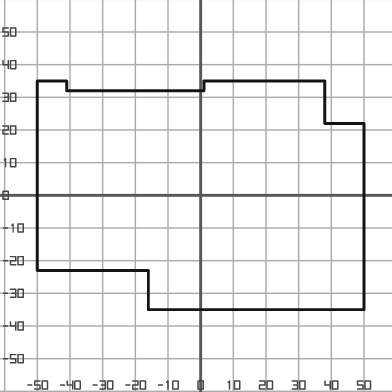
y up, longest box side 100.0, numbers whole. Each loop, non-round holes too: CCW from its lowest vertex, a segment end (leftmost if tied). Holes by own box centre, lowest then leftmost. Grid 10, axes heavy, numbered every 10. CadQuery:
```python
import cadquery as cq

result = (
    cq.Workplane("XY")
    .moveTo(-16.0, -35.0)
    .lineTo(50.0, -35.0)
    .lineTo(50.0, 22.0)
    .lineTo(38.0, 22.0)
    .lineTo(38.0, 35.0)
    .lineTo(1.0, 35.0)
    .lineTo(1.0, 32.0)
    .lineTo(-41.0, 32.0)
    .lineTo(-41.0, 35.0)
    .lineTo(-50.0, 35.0)
    .lineTo(-50.0, -23.0)
    .lineTo(-16.0, -23.0)
    .close()
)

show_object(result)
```